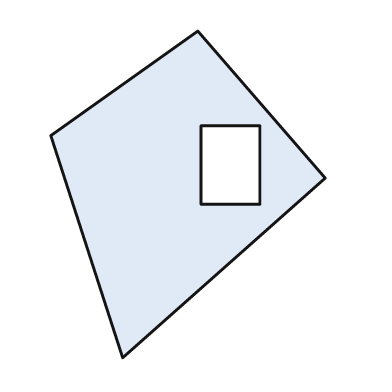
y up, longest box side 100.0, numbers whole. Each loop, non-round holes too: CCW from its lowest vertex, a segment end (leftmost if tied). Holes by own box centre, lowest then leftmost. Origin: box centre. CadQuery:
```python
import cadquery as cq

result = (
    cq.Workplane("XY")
    .moveTo(-20.0, -50.0)
    .lineTo(42.0, 5.0)
    .lineTo(3.0, 50.0)
    .lineTo(-42.0, 18.0)
    .close()
    .moveTo(4.0, -3.0)
    .lineTo(22.0, -3.0)
    .lineTo(22.0, 21.0)
    .lineTo(4.0, 21.0)
    .close()
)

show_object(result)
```